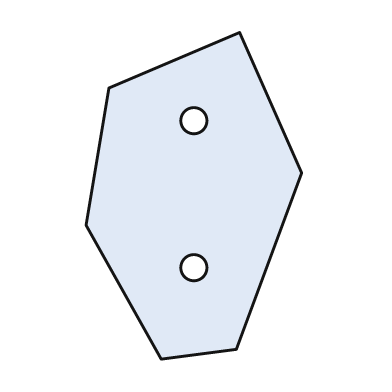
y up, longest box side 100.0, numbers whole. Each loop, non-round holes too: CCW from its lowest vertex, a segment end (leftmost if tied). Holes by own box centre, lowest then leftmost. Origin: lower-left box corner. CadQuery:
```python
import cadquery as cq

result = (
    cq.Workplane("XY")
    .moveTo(23.0, 0.0)
    .lineTo(46.0, 3.0)
    .lineTo(66.0, 57.0)
    .lineTo(47.0, 100.0)
    .lineTo(7.0, 83.0)
    .lineTo(0.0, 41.0)
    .close()
    .moveTo(33.0, 28.0)
    .circle(4.0)
    .moveTo(33.0, 73.0)
    .circle(4.0)
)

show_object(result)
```